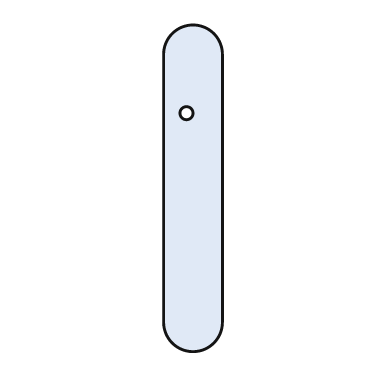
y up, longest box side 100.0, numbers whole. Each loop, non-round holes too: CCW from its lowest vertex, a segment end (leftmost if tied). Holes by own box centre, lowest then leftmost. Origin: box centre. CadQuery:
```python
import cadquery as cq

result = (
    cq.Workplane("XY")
    .moveTo(-9.0, -41.0)
    .threePointArc((0.0, -50.0), (9.0, -41.0))
    .lineTo(9.0, 41.0)
    .threePointArc((0.0, 50.0), (-9.0, 41.0))
    .close()
    .moveTo(-2.0, 23.0)
    .circle(2.0)
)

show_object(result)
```